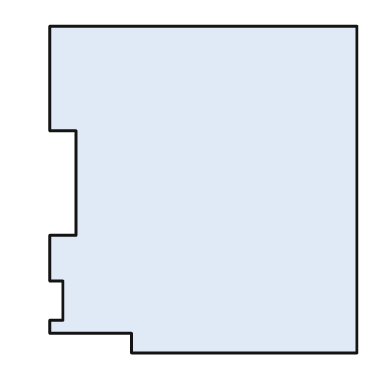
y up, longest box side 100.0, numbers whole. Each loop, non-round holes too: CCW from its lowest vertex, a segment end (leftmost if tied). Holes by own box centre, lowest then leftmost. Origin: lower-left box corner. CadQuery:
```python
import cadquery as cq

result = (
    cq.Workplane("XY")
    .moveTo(25.0, 0.0)
    .lineTo(94.0, 0.0)
    .lineTo(94.0, 100.0)
    .lineTo(0.0, 100.0)
    .lineTo(0.0, 68.0)
    .lineTo(8.0, 68.0)
    .lineTo(8.0, 36.0)
    .lineTo(0.0, 36.0)
    .lineTo(0.0, 22.0)
    .lineTo(4.0, 22.0)
    .lineTo(4.0, 10.0)
    .lineTo(0.0, 10.0)
    .lineTo(0.0, 6.0)
    .lineTo(25.0, 6.0)
    .close()
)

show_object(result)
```